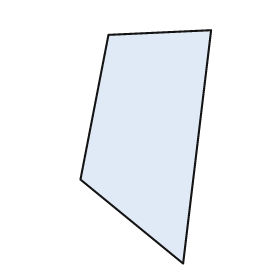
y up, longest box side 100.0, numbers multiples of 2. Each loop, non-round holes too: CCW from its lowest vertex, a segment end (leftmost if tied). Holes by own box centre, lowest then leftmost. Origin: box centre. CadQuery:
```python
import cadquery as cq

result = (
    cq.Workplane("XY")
    .moveTo(16.0, -50.0)
    .lineTo(28.0, 50.0)
    .lineTo(-16.0, 48.0)
    .lineTo(-28.0, -14.0)
    .close()
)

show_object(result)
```